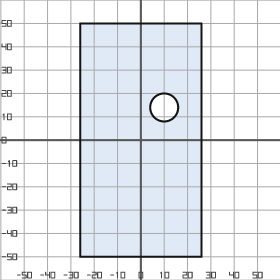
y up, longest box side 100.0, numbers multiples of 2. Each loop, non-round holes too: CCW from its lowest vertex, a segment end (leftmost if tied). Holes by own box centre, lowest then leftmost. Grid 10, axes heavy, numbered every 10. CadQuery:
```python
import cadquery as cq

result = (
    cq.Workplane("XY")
    .moveTo(-26.0, -50.0)
    .lineTo(26.0, -50.0)
    .lineTo(26.0, 50.0)
    .lineTo(-26.0, 50.0)
    .close()
    .moveTo(10.0, 14.0)
    .circle(6.0)
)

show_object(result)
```